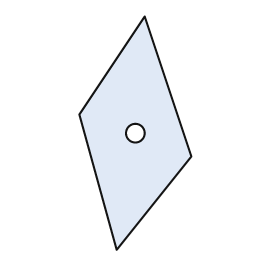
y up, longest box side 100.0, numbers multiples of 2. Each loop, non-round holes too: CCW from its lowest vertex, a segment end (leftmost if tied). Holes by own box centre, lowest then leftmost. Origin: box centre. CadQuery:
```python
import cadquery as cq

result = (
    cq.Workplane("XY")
    .moveTo(-8.0, -50.0)
    .lineTo(24.0, -10.0)
    .lineTo(4.0, 50.0)
    .lineTo(-24.0, 8.0)
    .close()
    .moveTo(0.0, 0.0)
    .circle(4.0)
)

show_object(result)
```